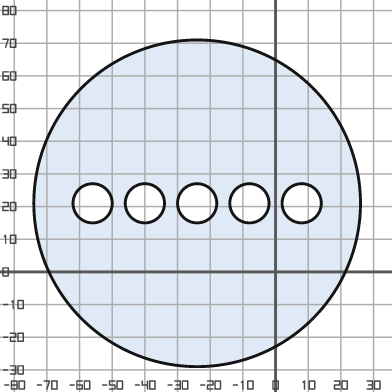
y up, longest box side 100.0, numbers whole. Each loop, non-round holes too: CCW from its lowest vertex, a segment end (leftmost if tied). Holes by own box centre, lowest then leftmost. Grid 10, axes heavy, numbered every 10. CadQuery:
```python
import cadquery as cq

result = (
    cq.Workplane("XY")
    .moveTo(-24.0, 21.0)
    .circle(50.0)
    .moveTo(-56.0, 21.0)
    .circle(6.0)
    .moveTo(-40.0, 21.0)
    .circle(6.0)
    .moveTo(-24.0, 21.0)
    .circle(6.0)
    .moveTo(-8.0, 21.0)
    .circle(6.0)
    .moveTo(8.0, 21.0)
    .circle(6.0)
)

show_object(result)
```